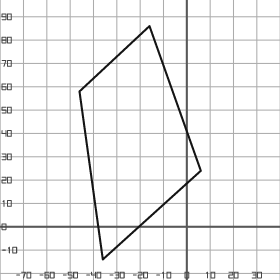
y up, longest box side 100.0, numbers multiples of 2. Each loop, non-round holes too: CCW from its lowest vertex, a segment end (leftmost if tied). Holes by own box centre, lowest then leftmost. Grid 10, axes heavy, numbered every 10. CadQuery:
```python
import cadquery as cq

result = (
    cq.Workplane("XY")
    .moveTo(-36.0, -14.0)
    .lineTo(6.0, 24.0)
    .lineTo(-16.0, 86.0)
    .lineTo(-46.0, 58.0)
    .close()
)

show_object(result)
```